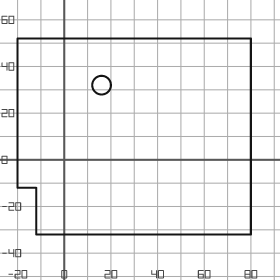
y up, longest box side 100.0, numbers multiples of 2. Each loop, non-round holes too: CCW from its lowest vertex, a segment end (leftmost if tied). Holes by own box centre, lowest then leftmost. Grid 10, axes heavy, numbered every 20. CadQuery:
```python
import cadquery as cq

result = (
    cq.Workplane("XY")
    .moveTo(-12.0, -32.0)
    .lineTo(80.0, -32.0)
    .lineTo(80.0, 52.0)
    .lineTo(-20.0, 52.0)
    .lineTo(-20.0, -12.0)
    .lineTo(-12.0, -12.0)
    .close()
    .moveTo(16.0, 32.0)
    .circle(4.0)
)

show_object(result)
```